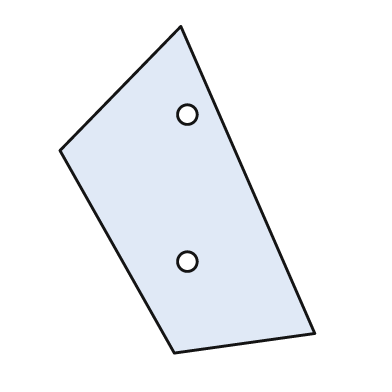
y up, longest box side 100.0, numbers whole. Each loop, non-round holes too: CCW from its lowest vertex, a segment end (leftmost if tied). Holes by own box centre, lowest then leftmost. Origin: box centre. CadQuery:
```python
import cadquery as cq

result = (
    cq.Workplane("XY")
    .moveTo(-4.0, -50.0)
    .lineTo(39.0, -44.0)
    .lineTo(-2.0, 50.0)
    .lineTo(-39.0, 12.0)
    .close()
    .moveTo(0.0, -22.0)
    .circle(3.0)
    .moveTo(0.0, 23.0)
    .circle(3.0)
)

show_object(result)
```